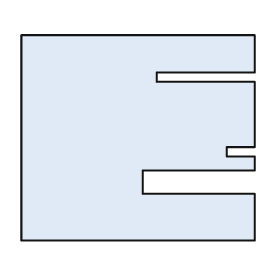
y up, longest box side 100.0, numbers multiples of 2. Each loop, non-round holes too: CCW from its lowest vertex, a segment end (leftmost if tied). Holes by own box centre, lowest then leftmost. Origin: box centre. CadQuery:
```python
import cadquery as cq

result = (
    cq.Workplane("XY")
    .moveTo(-50.0, -44.0)
    .lineTo(50.0, -44.0)
    .lineTo(50.0, -24.0)
    .lineTo(2.0, -24.0)
    .lineTo(2.0, -14.0)
    .lineTo(50.0, -14.0)
    .lineTo(50.0, -8.0)
    .lineTo(38.0, -8.0)
    .lineTo(38.0, -4.0)
    .lineTo(50.0, -4.0)
    .lineTo(50.0, 24.0)
    .lineTo(8.0, 24.0)
    .lineTo(8.0, 28.0)
    .lineTo(50.0, 28.0)
    .lineTo(50.0, 44.0)
    .lineTo(-50.0, 44.0)
    .close()
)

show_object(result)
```